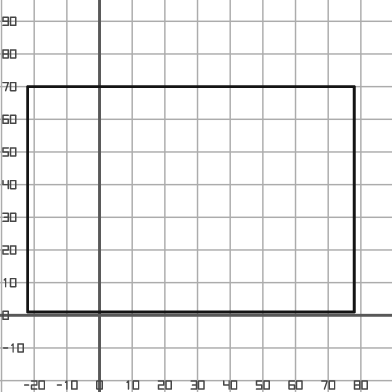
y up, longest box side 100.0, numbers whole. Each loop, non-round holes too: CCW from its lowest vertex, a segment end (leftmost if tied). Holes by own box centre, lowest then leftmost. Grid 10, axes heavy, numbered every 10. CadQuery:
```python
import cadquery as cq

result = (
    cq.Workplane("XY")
    .moveTo(-22.0, 1.0)
    .lineTo(78.0, 1.0)
    .lineTo(78.0, 70.0)
    .lineTo(-22.0, 70.0)
    .close()
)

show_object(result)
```